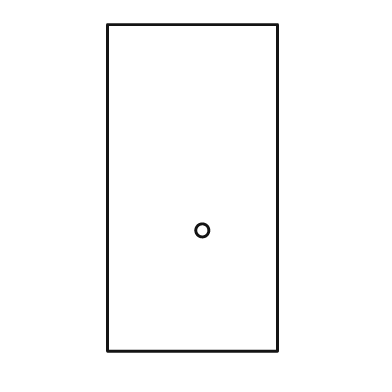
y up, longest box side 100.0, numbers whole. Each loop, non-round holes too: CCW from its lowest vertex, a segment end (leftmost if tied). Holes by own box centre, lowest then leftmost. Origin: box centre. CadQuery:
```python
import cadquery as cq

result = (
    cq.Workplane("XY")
    .moveTo(-26.0, -50.0)
    .lineTo(26.0, -50.0)
    .lineTo(26.0, 50.0)
    .lineTo(-26.0, 50.0)
    .close()
    .moveTo(3.0, -13.0)
    .circle(2.0)
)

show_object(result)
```